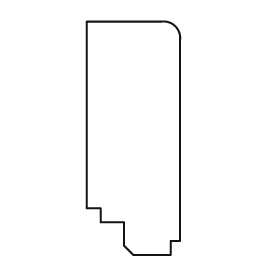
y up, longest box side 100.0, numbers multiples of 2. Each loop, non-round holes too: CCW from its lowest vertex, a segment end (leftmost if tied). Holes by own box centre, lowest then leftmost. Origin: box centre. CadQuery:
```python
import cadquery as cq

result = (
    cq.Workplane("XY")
    .moveTo(0.0, -50.0)
    .lineTo(16.0, -50.0)
    .lineTo(16.0, -44.0)
    .lineTo(20.0, -44.0)
    .lineTo(20.0, 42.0)
    .threePointArc((18.0, 48.0), (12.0, 50.0))
    .lineTo(-20.0, 50.0)
    .lineTo(-20.0, -30.0)
    .lineTo(-14.0, -30.0)
    .lineTo(-14.0, -36.0)
    .lineTo(-4.0, -36.0)
    .lineTo(-4.0, -46.0)
    .close()
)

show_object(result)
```